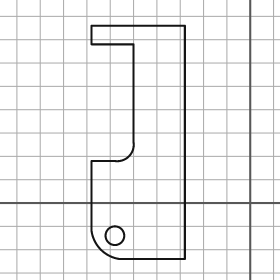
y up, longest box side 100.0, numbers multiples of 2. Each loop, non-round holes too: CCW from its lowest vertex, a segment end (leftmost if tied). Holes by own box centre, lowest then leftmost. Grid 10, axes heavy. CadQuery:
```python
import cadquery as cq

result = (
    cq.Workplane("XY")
    .moveTo(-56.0, -24.0)
    .lineTo(-28.0, -24.0)
    .lineTo(-28.0, 76.0)
    .lineTo(-68.0, 76.0)
    .lineTo(-68.0, 68.0)
    .lineTo(-50.0, 68.0)
    .lineTo(-50.0, 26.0)
    .threePointArc((-52.0, 20.0), (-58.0, 18.0))
    .lineTo(-68.0, 18.0)
    .lineTo(-68.0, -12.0)
    .threePointArc((-64.0, -20.0), (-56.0, -24.0))
    .close()
    .moveTo(-58.0, -14.0)
    .circle(4.0)
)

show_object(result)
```